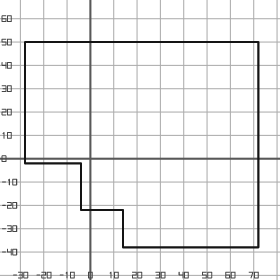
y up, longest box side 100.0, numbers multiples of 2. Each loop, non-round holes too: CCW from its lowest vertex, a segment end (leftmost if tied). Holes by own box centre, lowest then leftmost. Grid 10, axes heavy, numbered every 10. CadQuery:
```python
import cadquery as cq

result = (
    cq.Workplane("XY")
    .moveTo(14.0, -38.0)
    .lineTo(72.0, -38.0)
    .lineTo(72.0, 50.0)
    .lineTo(-28.0, 50.0)
    .lineTo(-28.0, -2.0)
    .lineTo(-4.0, -2.0)
    .lineTo(-4.0, -22.0)
    .lineTo(14.0, -22.0)
    .close()
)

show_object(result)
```